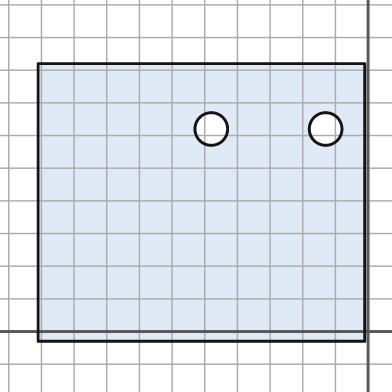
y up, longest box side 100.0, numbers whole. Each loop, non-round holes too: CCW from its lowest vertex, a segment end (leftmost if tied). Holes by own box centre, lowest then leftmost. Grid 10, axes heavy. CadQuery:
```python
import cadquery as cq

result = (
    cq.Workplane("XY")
    .moveTo(-101.0, -3.0)
    .lineTo(-1.0, -3.0)
    .lineTo(-1.0, 82.0)
    .lineTo(-101.0, 82.0)
    .close()
    .moveTo(-48.0, 62.0)
    .circle(5.0)
    .moveTo(-13.0, 62.0)
    .circle(5.0)
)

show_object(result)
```